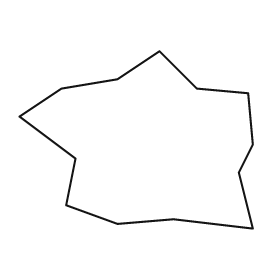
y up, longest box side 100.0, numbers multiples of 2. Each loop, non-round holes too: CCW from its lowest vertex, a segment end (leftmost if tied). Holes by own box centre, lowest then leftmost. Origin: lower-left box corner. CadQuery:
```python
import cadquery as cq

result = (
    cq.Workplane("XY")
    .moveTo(100.0, 0.0)
    .lineTo(94.0, 24.0)
    .lineTo(100.0, 36.0)
    .lineTo(98.0, 58.0)
    .lineTo(76.0, 60.0)
    .lineTo(60.0, 76.0)
    .lineTo(42.0, 64.0)
    .lineTo(18.0, 60.0)
    .lineTo(0.0, 48.0)
    .lineTo(24.0, 30.0)
    .lineTo(20.0, 10.0)
    .lineTo(42.0, 2.0)
    .lineTo(66.0, 4.0)
    .close()
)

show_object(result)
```